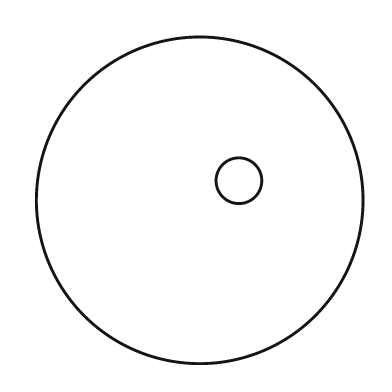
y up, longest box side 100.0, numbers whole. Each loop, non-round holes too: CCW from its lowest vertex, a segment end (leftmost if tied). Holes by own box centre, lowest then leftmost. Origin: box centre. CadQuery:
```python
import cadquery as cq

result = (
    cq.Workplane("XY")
    .moveTo(0.0, 0.0)
    .circle(50.0)
    .moveTo(12.0, 6.0)
    .circle(7.0)
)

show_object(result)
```